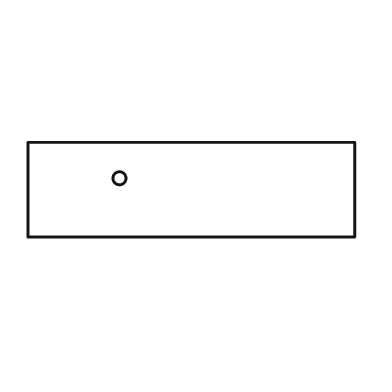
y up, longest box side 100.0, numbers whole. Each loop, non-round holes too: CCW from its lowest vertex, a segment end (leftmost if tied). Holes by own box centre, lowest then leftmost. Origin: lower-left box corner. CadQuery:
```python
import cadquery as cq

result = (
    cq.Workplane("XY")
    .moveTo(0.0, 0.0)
    .lineTo(100.0, 0.0)
    .lineTo(100.0, 29.0)
    .lineTo(0.0, 29.0)
    .close()
    .moveTo(28.0, 18.0)
    .circle(2.0)
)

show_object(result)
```